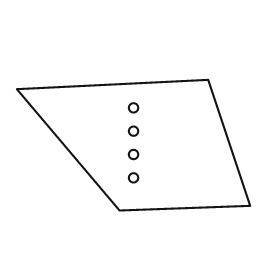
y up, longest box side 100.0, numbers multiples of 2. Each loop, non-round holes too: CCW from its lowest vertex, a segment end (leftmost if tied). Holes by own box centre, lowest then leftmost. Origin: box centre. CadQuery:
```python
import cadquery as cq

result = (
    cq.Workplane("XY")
    .moveTo(-6.0, -28.0)
    .lineTo(50.0, -26.0)
    .lineTo(32.0, 28.0)
    .lineTo(-50.0, 24.0)
    .close()
    .moveTo(0.0, -14.0)
    .circle(2.0)
    .moveTo(0.0, -4.0)
    .circle(2.0)
    .moveTo(0.0, 6.0)
    .circle(2.0)
    .moveTo(0.0, 16.0)
    .circle(2.0)
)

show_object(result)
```